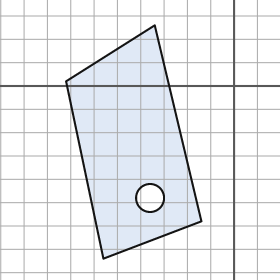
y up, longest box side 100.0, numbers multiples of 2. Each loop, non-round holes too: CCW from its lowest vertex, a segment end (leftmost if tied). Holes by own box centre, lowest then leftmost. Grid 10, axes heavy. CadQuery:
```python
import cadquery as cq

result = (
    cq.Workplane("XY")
    .moveTo(-56.0, -74.0)
    .lineTo(-14.0, -58.0)
    .lineTo(-34.0, 26.0)
    .lineTo(-72.0, 2.0)
    .close()
    .moveTo(-36.0, -48.0)
    .circle(6.0)
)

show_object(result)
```